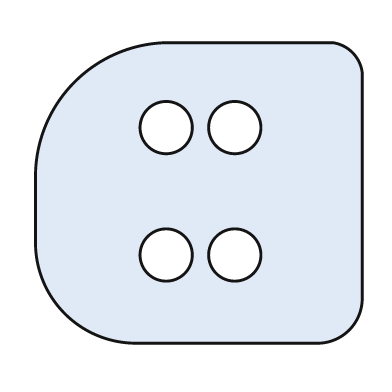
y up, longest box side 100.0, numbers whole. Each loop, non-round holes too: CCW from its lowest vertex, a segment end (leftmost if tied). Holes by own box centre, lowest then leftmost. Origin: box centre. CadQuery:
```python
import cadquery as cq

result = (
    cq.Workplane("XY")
    .moveTo(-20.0, -46.0)
    .lineTo(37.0, -46.0)
    .threePointArc((46.0, -42.0), (50.0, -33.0))
    .lineTo(50.0, 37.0)
    .threePointArc((47.0, 43.0), (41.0, 46.0))
    .lineTo(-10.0, 46.0)
    .threePointArc((-38.0, 34.0), (-50.0, 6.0))
    .lineTo(-50.0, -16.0)
    .threePointArc((-41.0, -37.0), (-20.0, -46.0))
    .close()
    .moveTo(-10.0, -19.0)
    .circle(8.0)
    .moveTo(11.0, -19.0)
    .circle(8.0)
    .moveTo(-10.0, 20.0)
    .circle(8.0)
    .moveTo(11.0, 20.0)
    .circle(8.0)
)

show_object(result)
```